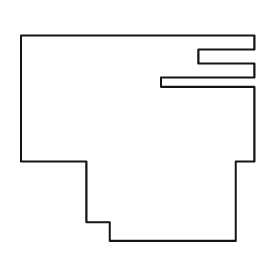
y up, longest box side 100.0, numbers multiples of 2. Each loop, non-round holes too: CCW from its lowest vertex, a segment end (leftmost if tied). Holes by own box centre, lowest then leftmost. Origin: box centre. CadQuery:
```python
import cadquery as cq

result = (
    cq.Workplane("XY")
    .moveTo(-12.0, -44.0)
    .lineTo(42.0, -44.0)
    .lineTo(42.0, -10.0)
    .lineTo(50.0, -10.0)
    .lineTo(50.0, 22.0)
    .lineTo(10.0, 22.0)
    .lineTo(10.0, 26.0)
    .lineTo(50.0, 26.0)
    .lineTo(50.0, 32.0)
    .lineTo(26.0, 32.0)
    .lineTo(26.0, 38.0)
    .lineTo(50.0, 38.0)
    .lineTo(50.0, 44.0)
    .lineTo(-50.0, 44.0)
    .lineTo(-50.0, -10.0)
    .lineTo(-22.0, -10.0)
    .lineTo(-22.0, -36.0)
    .lineTo(-12.0, -36.0)
    .close()
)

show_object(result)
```